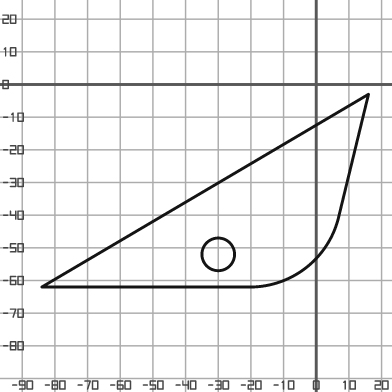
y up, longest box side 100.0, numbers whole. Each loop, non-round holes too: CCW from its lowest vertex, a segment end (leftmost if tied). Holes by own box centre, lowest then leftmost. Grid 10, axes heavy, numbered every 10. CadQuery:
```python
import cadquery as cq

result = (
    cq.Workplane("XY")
    .moveTo(-84.0, -62.0)
    .lineTo(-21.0, -62.0)
    .threePointArc((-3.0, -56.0), (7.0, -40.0))
    .lineTo(16.0, -3.0)
    .close()
    .moveTo(-30.0, -52.0)
    .circle(5.0)
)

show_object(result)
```